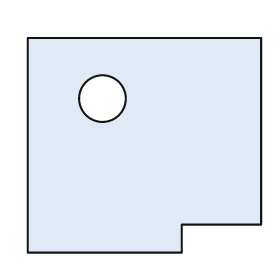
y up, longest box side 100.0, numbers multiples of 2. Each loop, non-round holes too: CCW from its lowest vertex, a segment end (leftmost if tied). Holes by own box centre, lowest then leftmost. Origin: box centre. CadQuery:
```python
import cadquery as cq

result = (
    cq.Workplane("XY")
    .moveTo(-50.0, -46.0)
    .lineTo(16.0, -46.0)
    .lineTo(16.0, -34.0)
    .lineTo(50.0, -34.0)
    .lineTo(50.0, 46.0)
    .lineTo(-50.0, 46.0)
    .close()
    .moveTo(-18.0, 20.0)
    .circle(10.0)
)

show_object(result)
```